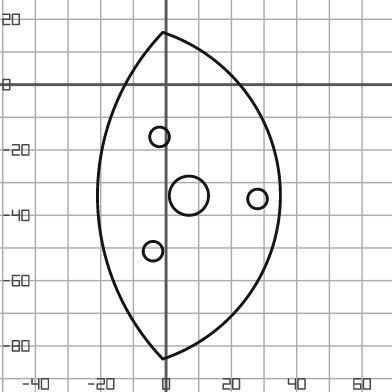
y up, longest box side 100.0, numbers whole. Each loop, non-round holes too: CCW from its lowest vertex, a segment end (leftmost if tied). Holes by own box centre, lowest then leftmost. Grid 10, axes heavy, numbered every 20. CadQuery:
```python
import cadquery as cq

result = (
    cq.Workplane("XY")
    .moveTo(-1.0, -84.0)
    .threePointArc((35.0, -34.0), (-1.0, 16.0))
    .threePointArc((-21.0, -34.0), (-1.0, -84.0))
    .close()
    .moveTo(-4.0, -51.0)
    .circle(3.0)
    .moveTo(28.0, -35.0)
    .circle(3.0)
    .moveTo(7.0, -34.0)
    .circle(6.0)
    .moveTo(-2.0, -16.0)
    .circle(3.0)
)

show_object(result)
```